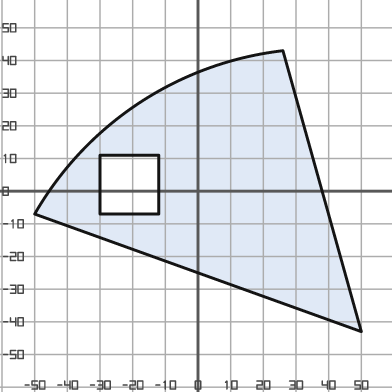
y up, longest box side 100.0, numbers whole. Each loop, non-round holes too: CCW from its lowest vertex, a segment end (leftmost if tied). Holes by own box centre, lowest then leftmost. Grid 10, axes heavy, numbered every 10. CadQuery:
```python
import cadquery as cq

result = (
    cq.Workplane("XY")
    .moveTo(50.0, -43.0)
    .lineTo(26.0, 43.0)
    .threePointArc((-18.0, 27.0), (-50.0, -7.0))
    .close()
    .moveTo(-30.0, -7.0)
    .lineTo(-12.0, -7.0)
    .lineTo(-12.0, 11.0)
    .lineTo(-30.0, 11.0)
    .close()
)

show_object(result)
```